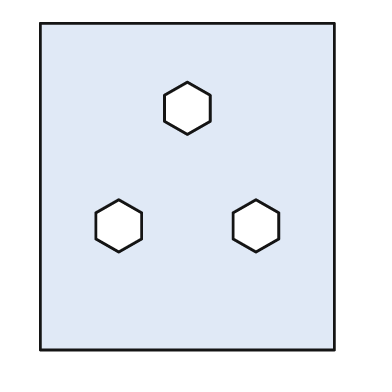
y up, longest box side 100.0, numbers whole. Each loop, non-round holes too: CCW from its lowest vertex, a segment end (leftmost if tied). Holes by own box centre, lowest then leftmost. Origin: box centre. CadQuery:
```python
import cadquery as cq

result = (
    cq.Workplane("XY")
    .moveTo(-45.0, -50.0)
    .lineTo(45.0, -50.0)
    .lineTo(45.0, 50.0)
    .lineTo(-45.0, 50.0)
    .close()
    .moveTo(-21.0, -20.0)
    .lineTo(-14.0, -16.0)
    .lineTo(-14.0, -8.0)
    .lineTo(-21.0, -4.0)
    .lineTo(-28.0, -8.0)
    .lineTo(-28.0, -16.0)
    .close()
    .moveTo(21.0, -20.0)
    .lineTo(28.0, -16.0)
    .lineTo(28.0, -8.0)
    .lineTo(21.0, -4.0)
    .lineTo(14.0, -8.0)
    .lineTo(14.0, -16.0)
    .close()
    .moveTo(0.0, 16.0)
    .lineTo(7.0, 20.0)
    .lineTo(7.0, 28.0)
    .lineTo(0.0, 32.0)
    .lineTo(-7.0, 28.0)
    .lineTo(-7.0, 20.0)
    .close()
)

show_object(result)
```